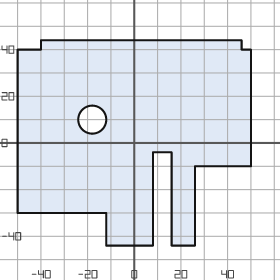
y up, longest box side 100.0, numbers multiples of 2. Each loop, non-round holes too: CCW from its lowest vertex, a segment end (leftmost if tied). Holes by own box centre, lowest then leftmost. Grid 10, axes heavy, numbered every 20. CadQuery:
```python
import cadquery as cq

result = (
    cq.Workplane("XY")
    .moveTo(-12.0, -44.0)
    .lineTo(8.0, -44.0)
    .lineTo(8.0, -4.0)
    .lineTo(16.0, -4.0)
    .lineTo(16.0, -44.0)
    .lineTo(26.0, -44.0)
    .lineTo(26.0, -10.0)
    .lineTo(50.0, -10.0)
    .lineTo(50.0, 40.0)
    .lineTo(46.0, 40.0)
    .lineTo(46.0, 44.0)
    .lineTo(-40.0, 44.0)
    .lineTo(-40.0, 40.0)
    .lineTo(-50.0, 40.0)
    .lineTo(-50.0, -30.0)
    .lineTo(-12.0, -30.0)
    .close()
    .moveTo(-18.0, 10.0)
    .circle(6.0)
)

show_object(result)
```